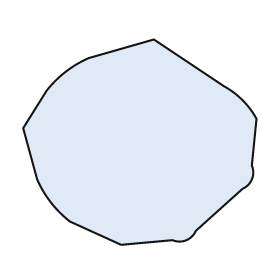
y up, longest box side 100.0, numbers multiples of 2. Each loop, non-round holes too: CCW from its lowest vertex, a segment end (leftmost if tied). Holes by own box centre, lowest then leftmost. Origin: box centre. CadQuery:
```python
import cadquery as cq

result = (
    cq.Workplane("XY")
    .moveTo(-8.0, -44.0)
    .lineTo(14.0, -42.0)
    .threePointArc((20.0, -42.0), (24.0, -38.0))
    .lineTo(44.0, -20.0)
    .threePointArc((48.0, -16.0), (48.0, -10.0))
    .lineTo(50.0, 10.0)
    .threePointArc((44.0, 18.0), (36.0, 24.0))
    .lineTo(6.0, 44.0)
    .lineTo(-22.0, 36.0)
    .threePointArc((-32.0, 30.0), (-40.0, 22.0))
    .lineTo(-50.0, 6.0)
    .lineTo(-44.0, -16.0)
    .threePointArc((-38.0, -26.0), (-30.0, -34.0))
    .close()
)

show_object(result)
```